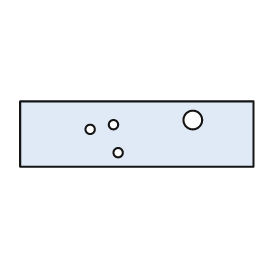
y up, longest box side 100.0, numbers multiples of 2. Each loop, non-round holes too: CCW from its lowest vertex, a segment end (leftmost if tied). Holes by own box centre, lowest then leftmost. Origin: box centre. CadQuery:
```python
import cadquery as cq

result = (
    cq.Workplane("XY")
    .moveTo(-50.0, -14.0)
    .lineTo(50.0, -14.0)
    .lineTo(50.0, 14.0)
    .lineTo(-50.0, 14.0)
    .close()
    .moveTo(-8.0, -8.0)
    .circle(2.0)
    .moveTo(-20.0, 2.0)
    .circle(2.0)
    .moveTo(-10.0, 4.0)
    .circle(2.0)
    .moveTo(24.0, 6.0)
    .circle(4.0)
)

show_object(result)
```